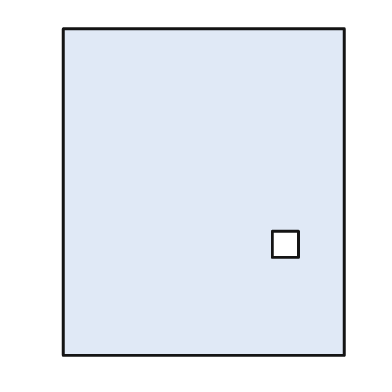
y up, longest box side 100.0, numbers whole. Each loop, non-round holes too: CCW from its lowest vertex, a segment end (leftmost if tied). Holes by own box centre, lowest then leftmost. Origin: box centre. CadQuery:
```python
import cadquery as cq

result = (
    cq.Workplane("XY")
    .moveTo(-43.0, -50.0)
    .lineTo(43.0, -50.0)
    .lineTo(43.0, 50.0)
    .lineTo(-43.0, 50.0)
    .close()
    .moveTo(21.0, -20.0)
    .lineTo(29.0, -20.0)
    .lineTo(29.0, -12.0)
    .lineTo(21.0, -12.0)
    .close()
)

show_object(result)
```